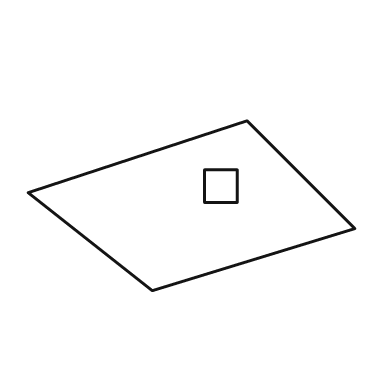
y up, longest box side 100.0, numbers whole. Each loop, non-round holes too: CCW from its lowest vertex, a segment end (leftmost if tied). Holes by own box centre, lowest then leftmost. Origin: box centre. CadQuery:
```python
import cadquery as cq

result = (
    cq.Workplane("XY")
    .moveTo(-12.0, -26.0)
    .lineTo(50.0, -7.0)
    .lineTo(17.0, 26.0)
    .lineTo(-50.0, 4.0)
    .close()
    .moveTo(4.0, 1.0)
    .lineTo(14.0, 1.0)
    .lineTo(14.0, 11.0)
    .lineTo(4.0, 11.0)
    .close()
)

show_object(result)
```